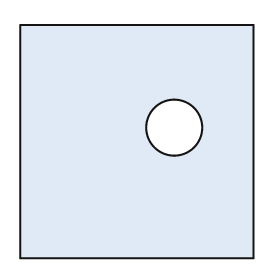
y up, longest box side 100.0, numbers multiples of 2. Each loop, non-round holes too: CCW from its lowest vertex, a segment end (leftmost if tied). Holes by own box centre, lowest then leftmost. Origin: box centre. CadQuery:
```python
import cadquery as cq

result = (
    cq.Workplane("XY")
    .moveTo(-50.0, -50.0)
    .lineTo(50.0, -50.0)
    .lineTo(50.0, 50.0)
    .lineTo(-50.0, 50.0)
    .close()
    .moveTo(16.0, 6.0)
    .circle(12.0)
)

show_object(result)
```